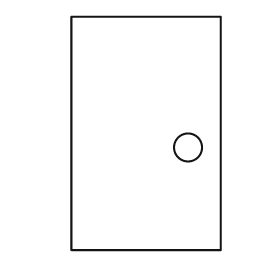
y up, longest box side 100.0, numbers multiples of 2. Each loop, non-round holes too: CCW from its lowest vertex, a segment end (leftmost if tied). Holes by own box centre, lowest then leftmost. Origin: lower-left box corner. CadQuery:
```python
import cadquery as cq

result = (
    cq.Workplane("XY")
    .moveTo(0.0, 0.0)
    .lineTo(64.0, 0.0)
    .lineTo(64.0, 100.0)
    .lineTo(0.0, 100.0)
    .close()
    .moveTo(50.0, 44.0)
    .circle(6.0)
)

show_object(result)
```